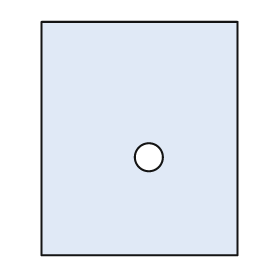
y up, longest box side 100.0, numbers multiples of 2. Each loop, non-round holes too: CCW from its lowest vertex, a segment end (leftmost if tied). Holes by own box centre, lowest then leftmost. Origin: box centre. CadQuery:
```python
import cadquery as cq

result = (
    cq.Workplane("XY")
    .moveTo(-42.0, -50.0)
    .lineTo(42.0, -50.0)
    .lineTo(42.0, 50.0)
    .lineTo(-42.0, 50.0)
    .close()
    .moveTo(4.0, -8.0)
    .circle(6.0)
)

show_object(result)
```